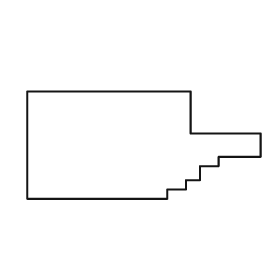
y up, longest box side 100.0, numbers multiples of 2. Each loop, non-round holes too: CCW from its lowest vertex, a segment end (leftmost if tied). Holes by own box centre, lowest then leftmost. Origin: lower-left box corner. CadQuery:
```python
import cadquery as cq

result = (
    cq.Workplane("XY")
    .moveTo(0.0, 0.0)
    .lineTo(60.0, 0.0)
    .lineTo(60.0, 4.0)
    .lineTo(68.0, 4.0)
    .lineTo(68.0, 8.0)
    .lineTo(74.0, 8.0)
    .lineTo(74.0, 14.0)
    .lineTo(82.0, 14.0)
    .lineTo(82.0, 18.0)
    .lineTo(100.0, 18.0)
    .lineTo(100.0, 28.0)
    .lineTo(70.0, 28.0)
    .lineTo(70.0, 46.0)
    .lineTo(0.0, 46.0)
    .close()
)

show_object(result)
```